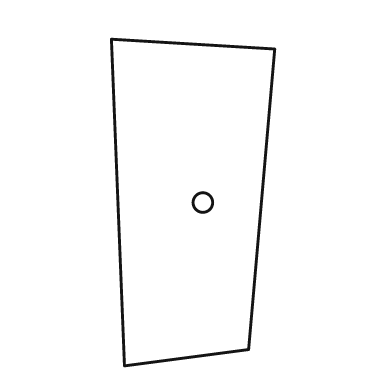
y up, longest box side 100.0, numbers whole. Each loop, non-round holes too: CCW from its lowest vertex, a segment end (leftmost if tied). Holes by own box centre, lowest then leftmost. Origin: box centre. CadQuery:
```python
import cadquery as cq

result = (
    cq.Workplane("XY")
    .moveTo(-21.0, -50.0)
    .lineTo(17.0, -45.0)
    .lineTo(25.0, 47.0)
    .lineTo(-25.0, 50.0)
    .close()
    .moveTo(3.0, 0.0)
    .circle(3.0)
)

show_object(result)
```